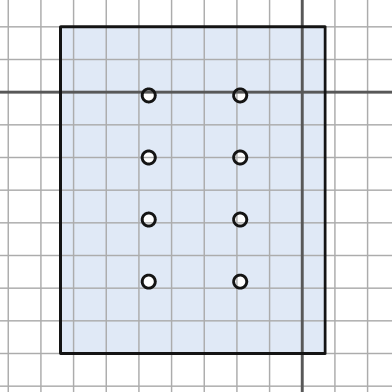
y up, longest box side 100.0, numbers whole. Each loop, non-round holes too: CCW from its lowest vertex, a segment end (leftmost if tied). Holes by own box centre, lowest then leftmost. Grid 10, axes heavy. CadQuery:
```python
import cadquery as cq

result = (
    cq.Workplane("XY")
    .moveTo(-74.0, -80.0)
    .lineTo(7.0, -80.0)
    .lineTo(7.0, 20.0)
    .lineTo(-74.0, 20.0)
    .close()
    .moveTo(-47.0, -58.0)
    .circle(2.0)
    .moveTo(-19.0, -58.0)
    .circle(2.0)
    .moveTo(-47.0, -39.0)
    .circle(2.0)
    .moveTo(-19.0, -39.0)
    .circle(2.0)
    .moveTo(-47.0, -20.0)
    .circle(2.0)
    .moveTo(-19.0, -20.0)
    .circle(2.0)
    .moveTo(-47.0, -1.0)
    .circle(2.0)
    .moveTo(-19.0, -1.0)
    .circle(2.0)
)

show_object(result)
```